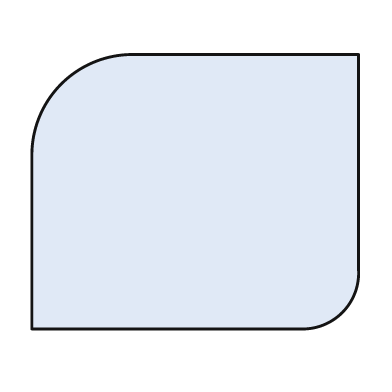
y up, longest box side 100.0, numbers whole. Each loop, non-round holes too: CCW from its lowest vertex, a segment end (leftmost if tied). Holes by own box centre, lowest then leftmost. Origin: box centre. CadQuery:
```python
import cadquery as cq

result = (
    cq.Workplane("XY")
    .moveTo(-50.0, -42.0)
    .lineTo(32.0, -42.0)
    .threePointArc((45.0, -37.0), (50.0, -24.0))
    .lineTo(50.0, 42.0)
    .lineTo(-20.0, 42.0)
    .threePointArc((-41.0, 33.0), (-50.0, 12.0))
    .close()
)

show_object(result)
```